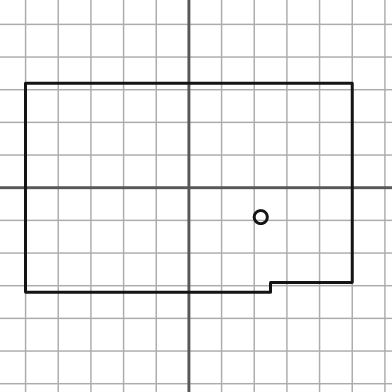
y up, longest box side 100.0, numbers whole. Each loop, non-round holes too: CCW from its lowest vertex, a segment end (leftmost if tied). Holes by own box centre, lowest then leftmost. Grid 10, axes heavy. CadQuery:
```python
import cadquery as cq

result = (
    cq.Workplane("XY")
    .moveTo(-50.0, -32.0)
    .lineTo(25.0, -32.0)
    .lineTo(25.0, -29.0)
    .lineTo(50.0, -29.0)
    .lineTo(50.0, 32.0)
    .lineTo(-50.0, 32.0)
    .close()
    .moveTo(22.0, -9.0)
    .circle(2.0)
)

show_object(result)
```